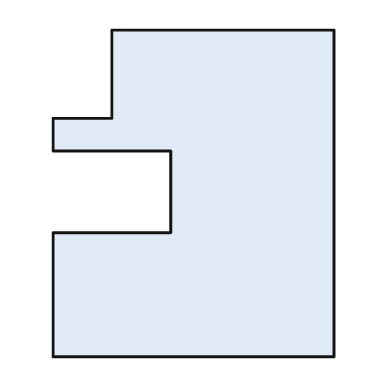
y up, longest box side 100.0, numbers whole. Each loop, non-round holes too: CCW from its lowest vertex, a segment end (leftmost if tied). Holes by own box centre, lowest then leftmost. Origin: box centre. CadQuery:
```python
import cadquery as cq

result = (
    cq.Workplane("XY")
    .moveTo(-43.0, -50.0)
    .lineTo(43.0, -50.0)
    .lineTo(43.0, 50.0)
    .lineTo(-25.0, 50.0)
    .lineTo(-25.0, 23.0)
    .lineTo(-43.0, 23.0)
    .lineTo(-43.0, 13.0)
    .lineTo(-7.0, 13.0)
    .lineTo(-7.0, -12.0)
    .lineTo(-43.0, -12.0)
    .close()
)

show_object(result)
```